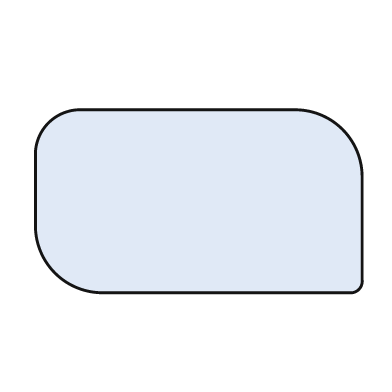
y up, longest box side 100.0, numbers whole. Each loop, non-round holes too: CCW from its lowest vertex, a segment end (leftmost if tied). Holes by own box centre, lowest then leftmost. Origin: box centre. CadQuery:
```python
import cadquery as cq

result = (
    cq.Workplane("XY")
    .moveTo(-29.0, -28.0)
    .lineTo(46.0, -28.0)
    .threePointArc((49.0, -27.0), (50.0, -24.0))
    .lineTo(50.0, 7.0)
    .threePointArc((44.0, 22.0), (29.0, 28.0))
    .lineTo(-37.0, 28.0)
    .threePointArc((-46.0, 24.0), (-50.0, 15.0))
    .lineTo(-50.0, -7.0)
    .threePointArc((-44.0, -22.0), (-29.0, -28.0))
    .close()
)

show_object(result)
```